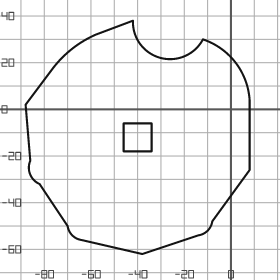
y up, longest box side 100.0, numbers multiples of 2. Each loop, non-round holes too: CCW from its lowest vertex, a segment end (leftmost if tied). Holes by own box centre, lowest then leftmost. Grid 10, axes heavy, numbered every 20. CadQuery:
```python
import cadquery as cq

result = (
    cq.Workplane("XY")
    .moveTo(-38.0, -62.0)
    .lineTo(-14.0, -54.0)
    .threePointArc((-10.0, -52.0), (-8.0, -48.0))
    .lineTo(8.0, -26.0)
    .lineTo(8.0, 4.0)
    .threePointArc((2.0, 20.0), (-12.0, 30.0))
    .threePointArc((-30.0, 22.0), (-42.0, 38.0))
    .lineTo(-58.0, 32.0)
    .threePointArc((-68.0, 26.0), (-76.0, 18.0))
    .lineTo(-88.0, 2.0)
    .lineTo(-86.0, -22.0)
    .threePointArc((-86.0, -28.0), (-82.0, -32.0))
    .lineTo(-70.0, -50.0)
    .threePointArc((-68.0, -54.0), (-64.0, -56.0))
    .close()
    .moveTo(-46.0, -18.0)
    .lineTo(-34.0, -18.0)
    .lineTo(-34.0, -6.0)
    .lineTo(-46.0, -6.0)
    .close()
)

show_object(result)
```